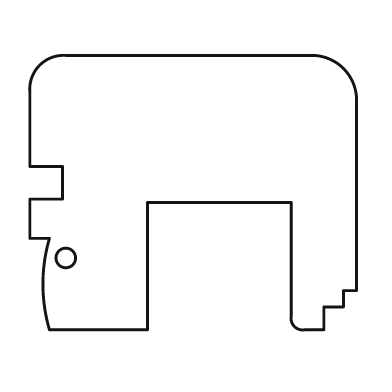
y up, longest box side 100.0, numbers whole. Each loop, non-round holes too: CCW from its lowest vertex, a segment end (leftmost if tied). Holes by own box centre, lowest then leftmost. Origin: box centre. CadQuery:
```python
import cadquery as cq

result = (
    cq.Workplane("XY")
    .moveTo(-44.0, -42.0)
    .lineTo(-14.0, -42.0)
    .lineTo(-14.0, -3.0)
    .lineTo(30.0, -3.0)
    .lineTo(30.0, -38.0)
    .threePointArc((31.0, -41.0), (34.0, -42.0))
    .lineTo(40.0, -42.0)
    .lineTo(40.0, -35.0)
    .lineTo(46.0, -35.0)
    .lineTo(46.0, -30.0)
    .lineTo(50.0, -30.0)
    .lineTo(50.0, 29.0)
    .threePointArc((46.0, 38.0), (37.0, 42.0))
    .lineTo(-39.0, 42.0)
    .threePointArc((-47.0, 39.0), (-50.0, 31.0))
    .lineTo(-50.0, 8.0)
    .lineTo(-40.0, 8.0)
    .lineTo(-40.0, -2.0)
    .lineTo(-50.0, -2.0)
    .lineTo(-50.0, -14.0)
    .lineTo(-44.0, -14.0)
    .threePointArc((-46.0, -28.0), (-44.0, -42.0))
    .close()
    .moveTo(-39.0, -20.0)
    .circle(3.0)
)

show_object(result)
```